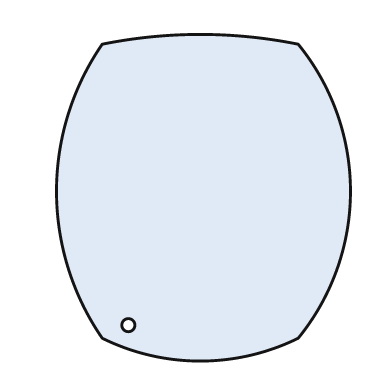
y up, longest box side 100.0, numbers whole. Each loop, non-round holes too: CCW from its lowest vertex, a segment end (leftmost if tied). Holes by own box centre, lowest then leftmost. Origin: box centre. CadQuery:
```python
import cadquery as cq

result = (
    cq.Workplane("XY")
    .moveTo(-31.0, -43.0)
    .threePointArc((-1.0, -50.0), (29.0, -43.0))
    .threePointArc((45.0, 2.0), (29.0, 47.0))
    .threePointArc((-1.0, 50.0), (-31.0, 47.0))
    .threePointArc((-45.0, 2.0), (-31.0, -43.0))
    .close()
    .moveTo(-23.0, -39.0)
    .circle(2.0)
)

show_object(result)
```